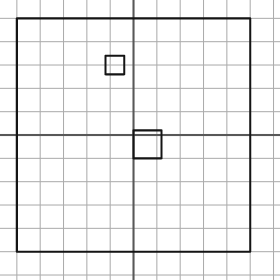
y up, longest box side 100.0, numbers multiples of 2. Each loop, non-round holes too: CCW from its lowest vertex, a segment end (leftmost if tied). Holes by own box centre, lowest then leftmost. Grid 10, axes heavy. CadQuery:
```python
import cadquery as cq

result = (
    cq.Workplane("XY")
    .moveTo(-50.0, -50.0)
    .lineTo(50.0, -50.0)
    .lineTo(50.0, 50.0)
    .lineTo(-50.0, 50.0)
    .close()
    .moveTo(0.0, -10.0)
    .lineTo(12.0, -10.0)
    .lineTo(12.0, 2.0)
    .lineTo(0.0, 2.0)
    .close()
    .moveTo(-12.0, 26.0)
    .lineTo(-4.0, 26.0)
    .lineTo(-4.0, 34.0)
    .lineTo(-12.0, 34.0)
    .close()
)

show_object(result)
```